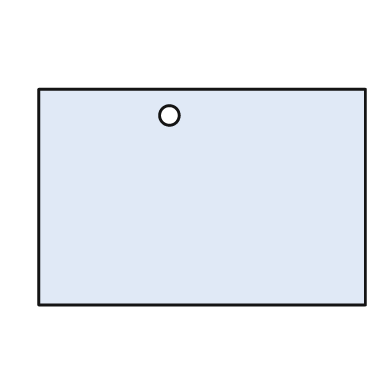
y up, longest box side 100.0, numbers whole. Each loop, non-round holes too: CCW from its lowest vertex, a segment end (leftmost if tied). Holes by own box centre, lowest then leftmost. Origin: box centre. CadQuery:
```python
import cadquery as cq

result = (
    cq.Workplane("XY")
    .moveTo(-50.0, -33.0)
    .lineTo(50.0, -33.0)
    .lineTo(50.0, 33.0)
    .lineTo(-50.0, 33.0)
    .close()
    .moveTo(-10.0, 25.0)
    .circle(3.0)
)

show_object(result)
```